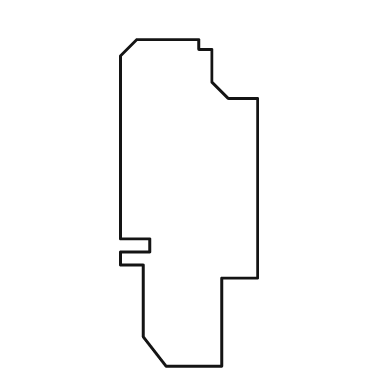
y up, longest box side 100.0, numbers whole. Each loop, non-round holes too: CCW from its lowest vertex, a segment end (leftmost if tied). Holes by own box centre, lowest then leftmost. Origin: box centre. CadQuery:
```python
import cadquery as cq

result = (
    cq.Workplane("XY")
    .moveTo(-7.0, -50.0)
    .lineTo(10.0, -50.0)
    .lineTo(10.0, -23.0)
    .lineTo(21.0, -23.0)
    .lineTo(21.0, 32.0)
    .lineTo(12.0, 32.0)
    .lineTo(7.0, 37.0)
    .lineTo(7.0, 47.0)
    .lineTo(3.0, 47.0)
    .lineTo(3.0, 50.0)
    .lineTo(-16.0, 50.0)
    .lineTo(-21.0, 45.0)
    .lineTo(-21.0, -11.0)
    .lineTo(-12.0, -11.0)
    .lineTo(-12.0, -15.0)
    .lineTo(-21.0, -15.0)
    .lineTo(-21.0, -19.0)
    .lineTo(-14.0, -19.0)
    .lineTo(-14.0, -41.0)
    .close()
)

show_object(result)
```